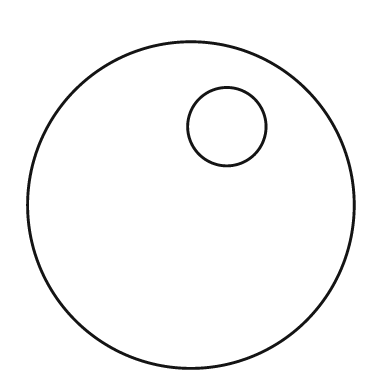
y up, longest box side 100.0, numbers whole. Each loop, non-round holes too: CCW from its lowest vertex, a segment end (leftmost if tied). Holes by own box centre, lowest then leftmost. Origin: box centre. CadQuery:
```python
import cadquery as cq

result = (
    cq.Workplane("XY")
    .moveTo(0.0, 0.0)
    .circle(50.0)
    .moveTo(11.0, 24.0)
    .circle(12.0)
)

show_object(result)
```